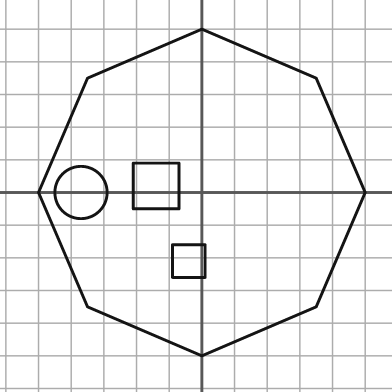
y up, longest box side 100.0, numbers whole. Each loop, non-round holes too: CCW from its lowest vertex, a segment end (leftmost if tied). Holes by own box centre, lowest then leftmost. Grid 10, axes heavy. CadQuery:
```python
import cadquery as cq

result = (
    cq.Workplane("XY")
    .moveTo(0.0, -50.0)
    .lineTo(35.0, -35.0)
    .lineTo(50.0, 0.0)
    .lineTo(35.0, 35.0)
    .lineTo(0.0, 50.0)
    .lineTo(-35.0, 35.0)
    .lineTo(-50.0, 0.0)
    .lineTo(-35.0, -35.0)
    .close()
    .moveTo(-9.0, -26.0)
    .lineTo(1.0, -26.0)
    .lineTo(1.0, -16.0)
    .lineTo(-9.0, -16.0)
    .close()
    .moveTo(-37.0, 0.0)
    .circle(8.0)
    .moveTo(-21.0, -5.0)
    .lineTo(-7.0, -5.0)
    .lineTo(-7.0, 9.0)
    .lineTo(-21.0, 9.0)
    .close()
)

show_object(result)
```